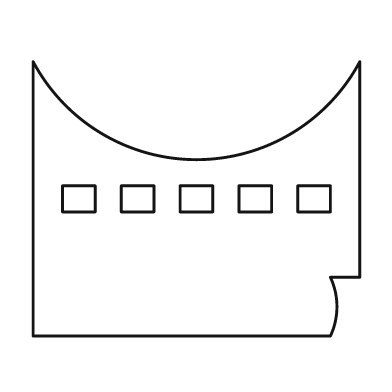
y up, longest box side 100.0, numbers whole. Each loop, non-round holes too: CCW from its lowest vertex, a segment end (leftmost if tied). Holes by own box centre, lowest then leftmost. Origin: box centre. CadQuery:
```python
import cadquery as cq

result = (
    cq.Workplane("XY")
    .moveTo(-50.0, -42.0)
    .lineTo(41.0, -42.0)
    .threePointArc((43.0, -33.0), (41.0, -24.0))
    .lineTo(50.0, -24.0)
    .lineTo(50.0, 42.0)
    .threePointArc((0.0, 12.0), (-50.0, 42.0))
    .close()
    .moveTo(-41.0, -4.0)
    .lineTo(-31.0, -4.0)
    .lineTo(-31.0, 4.0)
    .lineTo(-41.0, 4.0)
    .close()
    .moveTo(-23.0, -4.0)
    .lineTo(-13.0, -4.0)
    .lineTo(-13.0, 4.0)
    .lineTo(-23.0, 4.0)
    .close()
    .moveTo(-5.0, -4.0)
    .lineTo(5.0, -4.0)
    .lineTo(5.0, 4.0)
    .lineTo(-5.0, 4.0)
    .close()
    .moveTo(13.0, -4.0)
    .lineTo(23.0, -4.0)
    .lineTo(23.0, 4.0)
    .lineTo(13.0, 4.0)
    .close()
    .moveTo(31.0, -4.0)
    .lineTo(41.0, -4.0)
    .lineTo(41.0, 4.0)
    .lineTo(31.0, 4.0)
    .close()
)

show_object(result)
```